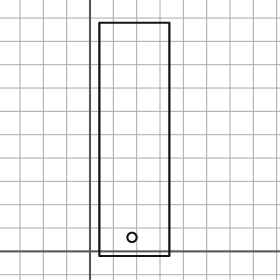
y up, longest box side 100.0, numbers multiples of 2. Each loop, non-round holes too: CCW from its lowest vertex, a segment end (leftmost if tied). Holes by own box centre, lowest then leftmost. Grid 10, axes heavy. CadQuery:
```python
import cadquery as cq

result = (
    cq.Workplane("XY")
    .moveTo(4.0, -2.0)
    .lineTo(34.0, -2.0)
    .lineTo(34.0, 98.0)
    .lineTo(4.0, 98.0)
    .close()
    .moveTo(18.0, 6.0)
    .circle(2.0)
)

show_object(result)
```